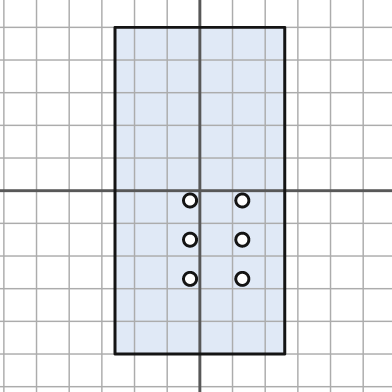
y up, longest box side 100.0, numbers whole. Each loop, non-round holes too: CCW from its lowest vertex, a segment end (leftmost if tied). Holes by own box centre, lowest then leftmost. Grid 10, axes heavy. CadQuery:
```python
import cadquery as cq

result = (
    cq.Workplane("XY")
    .moveTo(-26.0, -50.0)
    .lineTo(26.0, -50.0)
    .lineTo(26.0, 50.0)
    .lineTo(-26.0, 50.0)
    .close()
    .moveTo(-3.0, -27.0)
    .circle(2.0)
    .moveTo(13.0, -27.0)
    .circle(2.0)
    .moveTo(-3.0, -15.0)
    .circle(2.0)
    .moveTo(13.0, -15.0)
    .circle(2.0)
    .moveTo(-3.0, -3.0)
    .circle(2.0)
    .moveTo(13.0, -3.0)
    .circle(2.0)
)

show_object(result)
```